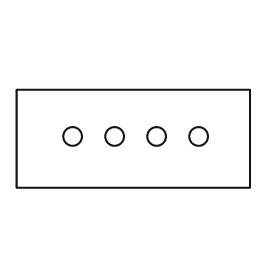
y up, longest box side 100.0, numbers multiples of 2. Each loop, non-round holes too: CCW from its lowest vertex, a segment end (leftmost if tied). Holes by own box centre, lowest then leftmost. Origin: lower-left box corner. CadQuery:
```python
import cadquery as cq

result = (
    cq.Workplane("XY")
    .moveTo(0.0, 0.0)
    .lineTo(100.0, 0.0)
    .lineTo(100.0, 42.0)
    .lineTo(0.0, 42.0)
    .close()
    .moveTo(24.0, 22.0)
    .circle(4.0)
    .moveTo(42.0, 22.0)
    .circle(4.0)
    .moveTo(60.0, 22.0)
    .circle(4.0)
    .moveTo(78.0, 22.0)
    .circle(4.0)
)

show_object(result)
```